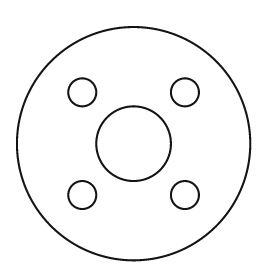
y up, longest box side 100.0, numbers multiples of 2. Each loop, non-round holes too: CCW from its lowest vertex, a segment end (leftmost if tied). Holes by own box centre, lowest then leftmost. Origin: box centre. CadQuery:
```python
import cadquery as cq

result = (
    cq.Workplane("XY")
    .moveTo(0.0, 0.0)
    .circle(50.0)
    .moveTo(-22.0, -22.0)
    .circle(6.0)
    .moveTo(22.0, -22.0)
    .circle(6.0)
    .moveTo(0.0, 0.0)
    .circle(16.0)
    .moveTo(-22.0, 22.0)
    .circle(6.0)
    .moveTo(22.0, 22.0)
    .circle(6.0)
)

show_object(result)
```